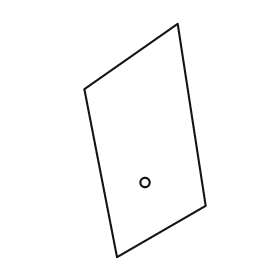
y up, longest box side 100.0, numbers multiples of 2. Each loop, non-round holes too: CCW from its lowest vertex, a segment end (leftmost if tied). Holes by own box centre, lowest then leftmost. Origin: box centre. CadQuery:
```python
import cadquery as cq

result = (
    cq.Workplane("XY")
    .moveTo(-12.0, -50.0)
    .lineTo(26.0, -28.0)
    .lineTo(14.0, 50.0)
    .lineTo(-26.0, 22.0)
    .close()
    .moveTo(0.0, -18.0)
    .circle(2.0)
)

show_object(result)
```